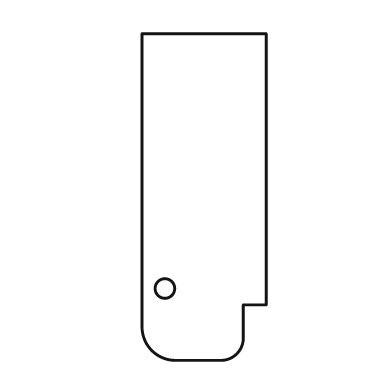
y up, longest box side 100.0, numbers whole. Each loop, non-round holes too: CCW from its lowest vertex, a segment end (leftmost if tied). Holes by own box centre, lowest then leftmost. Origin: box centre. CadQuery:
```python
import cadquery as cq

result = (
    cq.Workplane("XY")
    .moveTo(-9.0, -50.0)
    .lineTo(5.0, -50.0)
    .threePointArc((10.0, -48.0), (12.0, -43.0))
    .lineTo(12.0, -33.0)
    .lineTo(19.0, -33.0)
    .lineTo(19.0, 50.0)
    .lineTo(-19.0, 50.0)
    .lineTo(-19.0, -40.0)
    .threePointArc((-16.0, -47.0), (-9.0, -50.0))
    .close()
    .moveTo(-12.0, -28.0)
    .circle(3.0)
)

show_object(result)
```